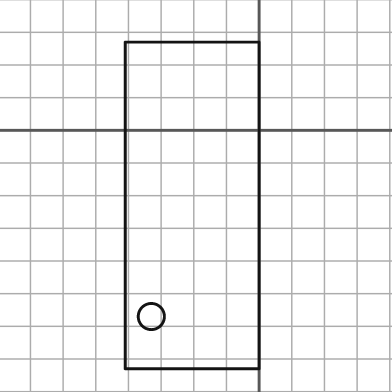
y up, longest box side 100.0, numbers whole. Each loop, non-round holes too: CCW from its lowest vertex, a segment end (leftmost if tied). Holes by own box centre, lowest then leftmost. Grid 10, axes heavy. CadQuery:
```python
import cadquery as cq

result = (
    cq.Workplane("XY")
    .moveTo(-41.0, -73.0)
    .lineTo(0.0, -73.0)
    .lineTo(0.0, 27.0)
    .lineTo(-41.0, 27.0)
    .close()
    .moveTo(-33.0, -57.0)
    .circle(4.0)
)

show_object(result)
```